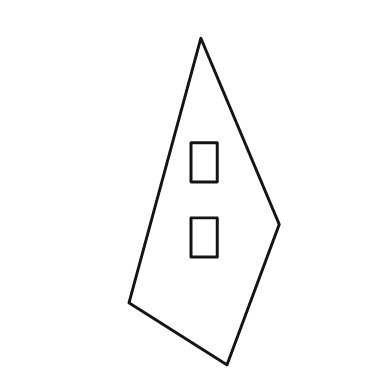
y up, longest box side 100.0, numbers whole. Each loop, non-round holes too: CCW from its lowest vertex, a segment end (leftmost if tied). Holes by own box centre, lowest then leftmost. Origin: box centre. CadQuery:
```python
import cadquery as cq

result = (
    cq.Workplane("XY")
    .moveTo(7.0, -50.0)
    .lineTo(23.0, -7.0)
    .lineTo(-1.0, 50.0)
    .lineTo(-23.0, -31.0)
    .close()
    .moveTo(-4.0, -17.0)
    .lineTo(4.0, -17.0)
    .lineTo(4.0, -5.0)
    .lineTo(-4.0, -5.0)
    .close()
    .moveTo(-4.0, 6.0)
    .lineTo(4.0, 6.0)
    .lineTo(4.0, 18.0)
    .lineTo(-4.0, 18.0)
    .close()
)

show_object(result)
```